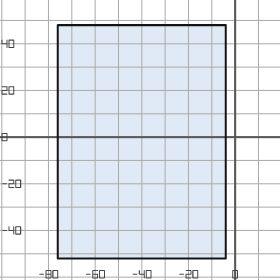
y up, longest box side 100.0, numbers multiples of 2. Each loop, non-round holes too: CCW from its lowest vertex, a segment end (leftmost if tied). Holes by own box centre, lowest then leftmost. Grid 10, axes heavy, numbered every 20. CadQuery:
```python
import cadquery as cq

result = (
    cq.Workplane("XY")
    .moveTo(-76.0, -52.0)
    .lineTo(-4.0, -52.0)
    .lineTo(-4.0, 48.0)
    .lineTo(-76.0, 48.0)
    .close()
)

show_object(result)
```